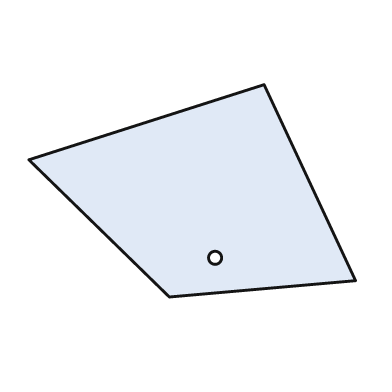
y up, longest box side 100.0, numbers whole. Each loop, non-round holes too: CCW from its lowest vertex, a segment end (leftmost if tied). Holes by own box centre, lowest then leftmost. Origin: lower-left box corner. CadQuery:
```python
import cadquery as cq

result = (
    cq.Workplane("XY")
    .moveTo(43.0, 0.0)
    .lineTo(100.0, 5.0)
    .lineTo(72.0, 65.0)
    .lineTo(0.0, 42.0)
    .close()
    .moveTo(57.0, 12.0)
    .circle(2.0)
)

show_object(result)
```